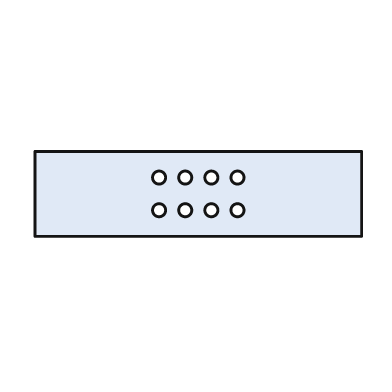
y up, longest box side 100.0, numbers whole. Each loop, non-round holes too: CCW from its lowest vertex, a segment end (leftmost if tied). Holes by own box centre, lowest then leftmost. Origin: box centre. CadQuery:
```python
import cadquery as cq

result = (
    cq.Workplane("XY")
    .moveTo(-50.0, -13.0)
    .lineTo(50.0, -13.0)
    .lineTo(50.0, 13.0)
    .lineTo(-50.0, 13.0)
    .close()
    .moveTo(-12.0, -5.0)
    .circle(2.0)
    .moveTo(-4.0, -5.0)
    .circle(2.0)
    .moveTo(4.0, -5.0)
    .circle(2.0)
    .moveTo(12.0, -5.0)
    .circle(2.0)
    .moveTo(-12.0, 5.0)
    .circle(2.0)
    .moveTo(-4.0, 5.0)
    .circle(2.0)
    .moveTo(4.0, 5.0)
    .circle(2.0)
    .moveTo(12.0, 5.0)
    .circle(2.0)
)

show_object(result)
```